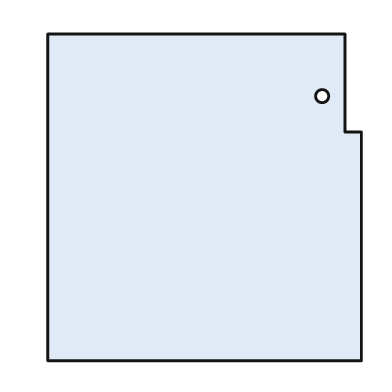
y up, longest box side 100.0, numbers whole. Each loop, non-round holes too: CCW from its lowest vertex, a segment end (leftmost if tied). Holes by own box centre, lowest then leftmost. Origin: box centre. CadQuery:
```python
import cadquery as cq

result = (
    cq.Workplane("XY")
    .moveTo(-48.0, -50.0)
    .lineTo(48.0, -50.0)
    .lineTo(48.0, 20.0)
    .lineTo(43.0, 20.0)
    .lineTo(43.0, 50.0)
    .lineTo(-48.0, 50.0)
    .close()
    .moveTo(36.0, 31.0)
    .circle(2.0)
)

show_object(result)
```